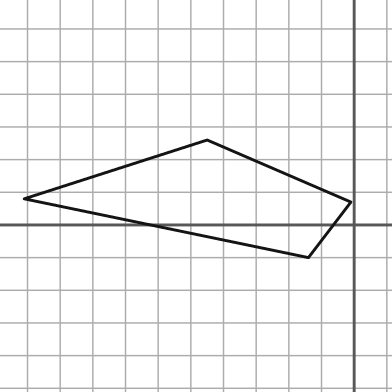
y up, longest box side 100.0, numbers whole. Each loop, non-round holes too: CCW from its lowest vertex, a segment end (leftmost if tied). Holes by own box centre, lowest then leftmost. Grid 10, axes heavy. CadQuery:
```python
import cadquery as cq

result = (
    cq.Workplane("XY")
    .moveTo(-14.0, -10.0)
    .lineTo(-1.0, 7.0)
    .lineTo(-45.0, 26.0)
    .lineTo(-101.0, 8.0)
    .close()
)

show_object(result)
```